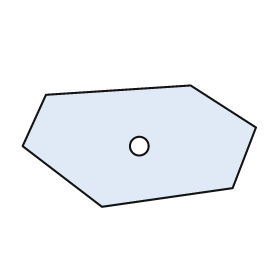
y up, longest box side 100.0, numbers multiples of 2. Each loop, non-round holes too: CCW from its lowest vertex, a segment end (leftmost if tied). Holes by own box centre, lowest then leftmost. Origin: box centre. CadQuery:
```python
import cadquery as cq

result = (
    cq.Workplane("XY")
    .moveTo(-16.0, -26.0)
    .lineTo(40.0, -18.0)
    .lineTo(50.0, 8.0)
    .lineTo(22.0, 26.0)
    .lineTo(-40.0, 22.0)
    .lineTo(-50.0, 0.0)
    .close()
    .moveTo(0.0, 0.0)
    .circle(4.0)
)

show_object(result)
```